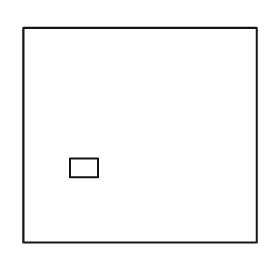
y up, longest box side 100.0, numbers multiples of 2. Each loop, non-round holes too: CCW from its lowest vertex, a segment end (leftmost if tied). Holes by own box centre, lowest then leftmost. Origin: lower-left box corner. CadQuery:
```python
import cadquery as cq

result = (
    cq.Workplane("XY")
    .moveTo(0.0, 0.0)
    .lineTo(100.0, 0.0)
    .lineTo(100.0, 92.0)
    .lineTo(0.0, 92.0)
    .close()
    .moveTo(20.0, 28.0)
    .lineTo(32.0, 28.0)
    .lineTo(32.0, 36.0)
    .lineTo(20.0, 36.0)
    .close()
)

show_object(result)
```